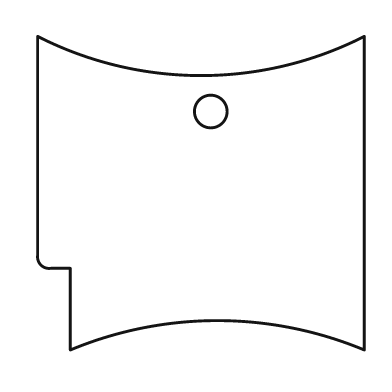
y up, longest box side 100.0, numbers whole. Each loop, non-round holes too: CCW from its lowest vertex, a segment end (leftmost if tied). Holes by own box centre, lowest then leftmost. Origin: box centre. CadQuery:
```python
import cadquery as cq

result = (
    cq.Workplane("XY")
    .moveTo(-40.0, -48.0)
    .threePointArc((5.0, -39.0), (50.0, -48.0))
    .lineTo(50.0, 48.0)
    .threePointArc((0.0, 36.0), (-50.0, 48.0))
    .lineTo(-50.0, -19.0)
    .threePointArc((-49.0, -22.0), (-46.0, -23.0))
    .lineTo(-40.0, -23.0)
    .close()
    .moveTo(3.0, 25.0)
    .circle(5.0)
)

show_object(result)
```